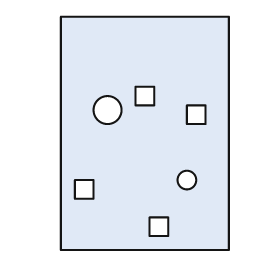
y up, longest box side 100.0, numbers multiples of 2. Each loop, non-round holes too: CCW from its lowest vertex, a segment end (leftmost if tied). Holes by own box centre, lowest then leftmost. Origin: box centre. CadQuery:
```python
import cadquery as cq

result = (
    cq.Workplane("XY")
    .moveTo(-36.0, -50.0)
    .lineTo(36.0, -50.0)
    .lineTo(36.0, 50.0)
    .lineTo(-36.0, 50.0)
    .close()
    .moveTo(2.0, -44.0)
    .lineTo(10.0, -44.0)
    .lineTo(10.0, -36.0)
    .lineTo(2.0, -36.0)
    .close()
    .moveTo(-30.0, -28.0)
    .lineTo(-22.0, -28.0)
    .lineTo(-22.0, -20.0)
    .lineTo(-30.0, -20.0)
    .close()
    .moveTo(18.0, -20.0)
    .circle(4.0)
    .moveTo(18.0, 4.0)
    .lineTo(26.0, 4.0)
    .lineTo(26.0, 12.0)
    .lineTo(18.0, 12.0)
    .close()
    .moveTo(-16.0, 10.0)
    .circle(6.0)
    .moveTo(-4.0, 12.0)
    .lineTo(4.0, 12.0)
    .lineTo(4.0, 20.0)
    .lineTo(-4.0, 20.0)
    .close()
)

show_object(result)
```